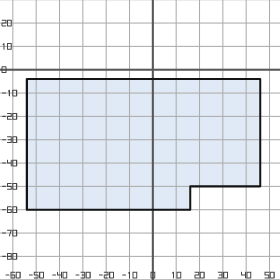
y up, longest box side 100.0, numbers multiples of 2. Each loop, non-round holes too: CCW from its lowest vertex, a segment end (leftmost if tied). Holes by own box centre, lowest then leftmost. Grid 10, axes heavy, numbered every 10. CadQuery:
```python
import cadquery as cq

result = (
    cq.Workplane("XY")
    .moveTo(-54.0, -60.0)
    .lineTo(16.0, -60.0)
    .lineTo(16.0, -50.0)
    .lineTo(46.0, -50.0)
    .lineTo(46.0, -4.0)
    .lineTo(-54.0, -4.0)
    .close()
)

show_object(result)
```